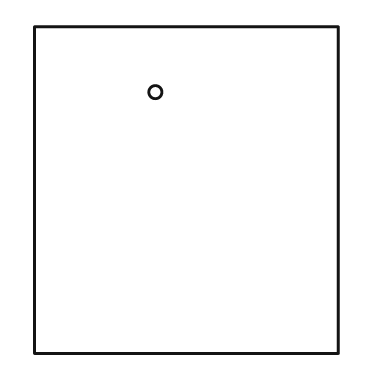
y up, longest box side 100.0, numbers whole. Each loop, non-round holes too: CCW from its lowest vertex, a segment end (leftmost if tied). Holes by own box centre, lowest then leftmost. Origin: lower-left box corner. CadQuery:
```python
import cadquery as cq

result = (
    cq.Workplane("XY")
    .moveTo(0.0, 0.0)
    .lineTo(93.0, 0.0)
    .lineTo(93.0, 100.0)
    .lineTo(0.0, 100.0)
    .close()
    .moveTo(37.0, 80.0)
    .circle(2.0)
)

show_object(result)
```